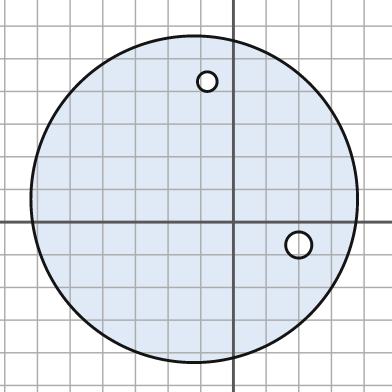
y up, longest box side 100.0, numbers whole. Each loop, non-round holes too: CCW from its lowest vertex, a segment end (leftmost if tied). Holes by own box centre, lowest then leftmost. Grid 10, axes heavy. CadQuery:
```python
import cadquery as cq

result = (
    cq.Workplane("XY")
    .moveTo(-12.0, 7.0)
    .circle(50.0)
    .moveTo(20.0, -7.0)
    .circle(4.0)
    .moveTo(-8.0, 43.0)
    .circle(3.0)
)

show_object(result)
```